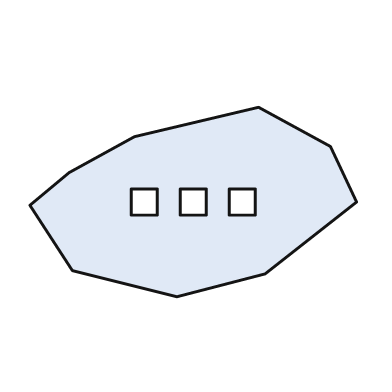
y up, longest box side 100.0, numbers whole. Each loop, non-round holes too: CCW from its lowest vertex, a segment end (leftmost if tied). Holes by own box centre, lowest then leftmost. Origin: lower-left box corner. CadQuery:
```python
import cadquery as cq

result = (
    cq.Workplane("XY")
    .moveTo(45.0, 0.0)
    .lineTo(72.0, 7.0)
    .lineTo(100.0, 29.0)
    .lineTo(92.0, 46.0)
    .lineTo(70.0, 58.0)
    .lineTo(32.0, 49.0)
    .lineTo(12.0, 38.0)
    .lineTo(0.0, 28.0)
    .lineTo(13.0, 8.0)
    .close()
    .moveTo(31.0, 25.0)
    .lineTo(39.0, 25.0)
    .lineTo(39.0, 33.0)
    .lineTo(31.0, 33.0)
    .close()
    .moveTo(46.0, 25.0)
    .lineTo(54.0, 25.0)
    .lineTo(54.0, 33.0)
    .lineTo(46.0, 33.0)
    .close()
    .moveTo(61.0, 25.0)
    .lineTo(69.0, 25.0)
    .lineTo(69.0, 33.0)
    .lineTo(61.0, 33.0)
    .close()
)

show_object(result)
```